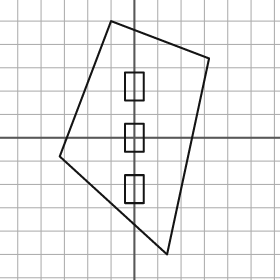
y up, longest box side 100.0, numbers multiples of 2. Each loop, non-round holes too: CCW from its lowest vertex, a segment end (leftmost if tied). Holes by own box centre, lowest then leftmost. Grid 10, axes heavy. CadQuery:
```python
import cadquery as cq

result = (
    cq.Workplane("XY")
    .moveTo(14.0, -50.0)
    .lineTo(32.0, 34.0)
    .lineTo(-10.0, 50.0)
    .lineTo(-32.0, -8.0)
    .close()
    .moveTo(-4.0, -28.0)
    .lineTo(4.0, -28.0)
    .lineTo(4.0, -16.0)
    .lineTo(-4.0, -16.0)
    .close()
    .moveTo(-4.0, -6.0)
    .lineTo(4.0, -6.0)
    .lineTo(4.0, 6.0)
    .lineTo(-4.0, 6.0)
    .close()
    .moveTo(-4.0, 16.0)
    .lineTo(4.0, 16.0)
    .lineTo(4.0, 28.0)
    .lineTo(-4.0, 28.0)
    .close()
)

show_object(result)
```